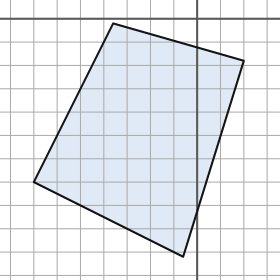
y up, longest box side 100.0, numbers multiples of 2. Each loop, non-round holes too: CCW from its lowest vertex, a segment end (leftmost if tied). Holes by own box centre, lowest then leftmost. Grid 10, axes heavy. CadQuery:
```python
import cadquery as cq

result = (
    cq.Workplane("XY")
    .moveTo(-6.0, -102.0)
    .lineTo(20.0, -18.0)
    .lineTo(-36.0, -2.0)
    .lineTo(-70.0, -70.0)
    .close()
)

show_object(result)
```